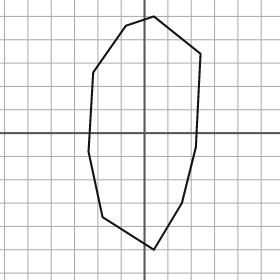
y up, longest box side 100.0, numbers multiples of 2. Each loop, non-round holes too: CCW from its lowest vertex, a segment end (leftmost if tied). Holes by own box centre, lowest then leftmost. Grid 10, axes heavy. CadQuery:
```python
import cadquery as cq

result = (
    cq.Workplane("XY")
    .moveTo(4.0, -50.0)
    .lineTo(16.0, -30.0)
    .lineTo(22.0, -6.0)
    .lineTo(24.0, 34.0)
    .lineTo(4.0, 50.0)
    .lineTo(-8.0, 46.0)
    .lineTo(-22.0, 26.0)
    .lineTo(-24.0, -8.0)
    .lineTo(-18.0, -36.0)
    .close()
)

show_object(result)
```